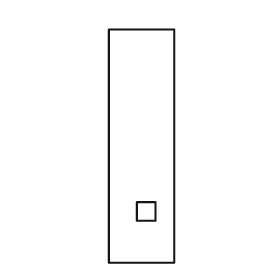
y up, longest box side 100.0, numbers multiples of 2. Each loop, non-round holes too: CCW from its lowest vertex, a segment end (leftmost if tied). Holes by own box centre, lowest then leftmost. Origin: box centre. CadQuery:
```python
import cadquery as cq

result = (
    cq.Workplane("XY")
    .moveTo(-14.0, -50.0)
    .lineTo(14.0, -50.0)
    .lineTo(14.0, 50.0)
    .lineTo(-14.0, 50.0)
    .close()
    .moveTo(-2.0, -32.0)
    .lineTo(6.0, -32.0)
    .lineTo(6.0, -24.0)
    .lineTo(-2.0, -24.0)
    .close()
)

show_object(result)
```